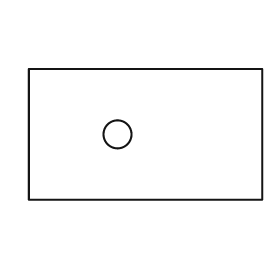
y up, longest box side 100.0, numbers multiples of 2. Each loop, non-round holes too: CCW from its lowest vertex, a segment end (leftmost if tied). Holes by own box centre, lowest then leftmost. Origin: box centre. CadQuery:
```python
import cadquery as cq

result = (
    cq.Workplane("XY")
    .moveTo(-50.0, -28.0)
    .lineTo(50.0, -28.0)
    .lineTo(50.0, 28.0)
    .lineTo(-50.0, 28.0)
    .close()
    .moveTo(-12.0, 0.0)
    .circle(6.0)
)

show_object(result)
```